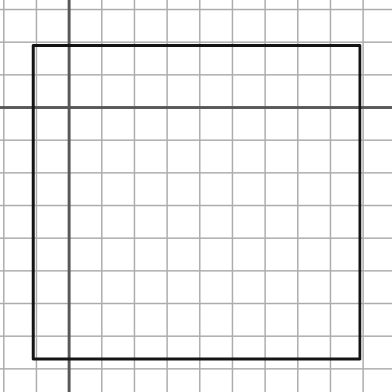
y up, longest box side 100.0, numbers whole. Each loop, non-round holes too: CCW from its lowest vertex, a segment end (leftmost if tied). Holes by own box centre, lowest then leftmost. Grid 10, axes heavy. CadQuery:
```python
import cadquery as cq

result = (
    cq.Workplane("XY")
    .moveTo(-11.0, -77.0)
    .lineTo(89.0, -77.0)
    .lineTo(89.0, 19.0)
    .lineTo(-11.0, 19.0)
    .close()
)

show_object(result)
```